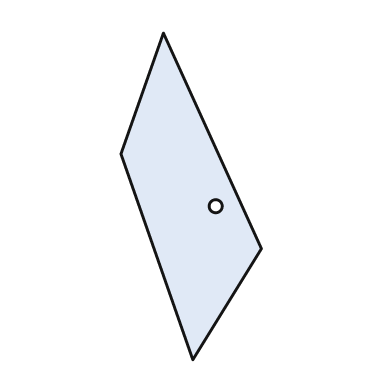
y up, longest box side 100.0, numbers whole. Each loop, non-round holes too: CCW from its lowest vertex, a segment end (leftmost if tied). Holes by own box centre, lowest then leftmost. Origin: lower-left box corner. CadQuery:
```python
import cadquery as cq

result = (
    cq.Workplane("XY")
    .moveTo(22.0, 0.0)
    .lineTo(43.0, 34.0)
    .lineTo(13.0, 100.0)
    .lineTo(0.0, 63.0)
    .close()
    .moveTo(29.0, 47.0)
    .circle(2.0)
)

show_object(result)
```